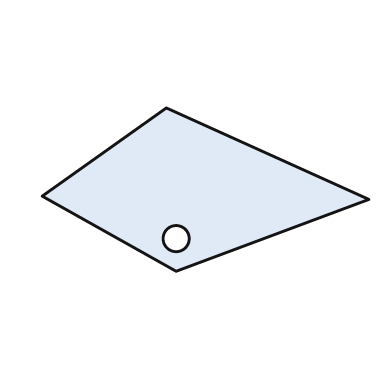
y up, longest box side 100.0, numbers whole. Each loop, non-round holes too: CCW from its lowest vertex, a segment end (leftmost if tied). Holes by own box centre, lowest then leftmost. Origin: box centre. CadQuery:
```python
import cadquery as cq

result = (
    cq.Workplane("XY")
    .moveTo(-9.0, -25.0)
    .lineTo(50.0, -3.0)
    .lineTo(-12.0, 25.0)
    .lineTo(-50.0, -2.0)
    .close()
    .moveTo(-9.0, -15.0)
    .circle(4.0)
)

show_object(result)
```